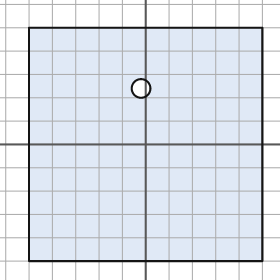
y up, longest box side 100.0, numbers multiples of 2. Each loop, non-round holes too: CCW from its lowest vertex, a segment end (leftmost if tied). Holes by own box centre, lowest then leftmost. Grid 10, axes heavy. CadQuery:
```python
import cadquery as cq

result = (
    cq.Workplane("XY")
    .moveTo(-50.0, -50.0)
    .lineTo(50.0, -50.0)
    .lineTo(50.0, 50.0)
    .lineTo(-50.0, 50.0)
    .close()
    .moveTo(-2.0, 24.0)
    .circle(4.0)
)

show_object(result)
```